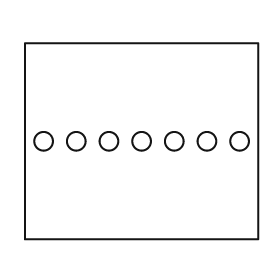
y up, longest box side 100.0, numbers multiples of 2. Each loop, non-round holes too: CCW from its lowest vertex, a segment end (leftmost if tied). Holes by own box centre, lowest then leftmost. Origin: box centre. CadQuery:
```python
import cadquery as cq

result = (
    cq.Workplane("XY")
    .moveTo(-50.0, -42.0)
    .lineTo(50.0, -42.0)
    .lineTo(50.0, 42.0)
    .lineTo(-50.0, 42.0)
    .close()
    .moveTo(-42.0, 0.0)
    .circle(4.0)
    .moveTo(-28.0, 0.0)
    .circle(4.0)
    .moveTo(-14.0, 0.0)
    .circle(4.0)
    .moveTo(0.0, 0.0)
    .circle(4.0)
    .moveTo(14.0, 0.0)
    .circle(4.0)
    .moveTo(28.0, 0.0)
    .circle(4.0)
    .moveTo(42.0, 0.0)
    .circle(4.0)
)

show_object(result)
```